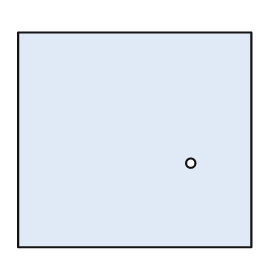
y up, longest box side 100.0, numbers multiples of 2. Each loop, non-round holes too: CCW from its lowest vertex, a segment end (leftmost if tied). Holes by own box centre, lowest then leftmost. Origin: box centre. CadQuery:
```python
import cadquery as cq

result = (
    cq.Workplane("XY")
    .moveTo(-50.0, -46.0)
    .lineTo(50.0, -46.0)
    .lineTo(50.0, 46.0)
    .lineTo(-50.0, 46.0)
    .close()
    .moveTo(24.0, -10.0)
    .circle(2.0)
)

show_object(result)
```